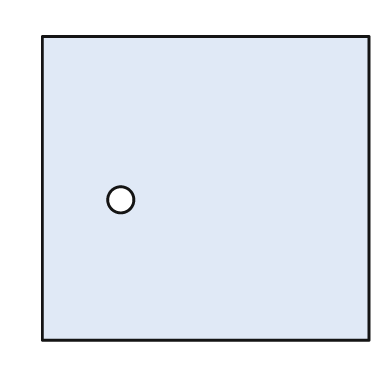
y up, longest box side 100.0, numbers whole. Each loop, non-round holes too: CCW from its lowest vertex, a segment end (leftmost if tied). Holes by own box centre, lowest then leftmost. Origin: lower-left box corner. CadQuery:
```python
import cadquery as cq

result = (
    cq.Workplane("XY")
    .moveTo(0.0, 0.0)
    .lineTo(100.0, 0.0)
    .lineTo(100.0, 93.0)
    .lineTo(0.0, 93.0)
    .close()
    .moveTo(24.0, 43.0)
    .circle(4.0)
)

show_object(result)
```